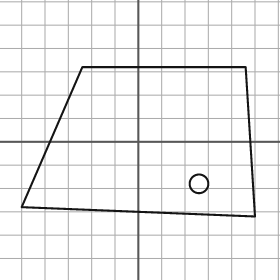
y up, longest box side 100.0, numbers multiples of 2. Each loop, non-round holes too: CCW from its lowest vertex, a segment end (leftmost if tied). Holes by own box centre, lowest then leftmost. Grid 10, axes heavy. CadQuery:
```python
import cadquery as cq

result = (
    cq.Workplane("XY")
    .moveTo(50.0, -32.0)
    .lineTo(46.0, 32.0)
    .lineTo(-24.0, 32.0)
    .lineTo(-50.0, -28.0)
    .close()
    .moveTo(26.0, -18.0)
    .circle(4.0)
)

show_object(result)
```